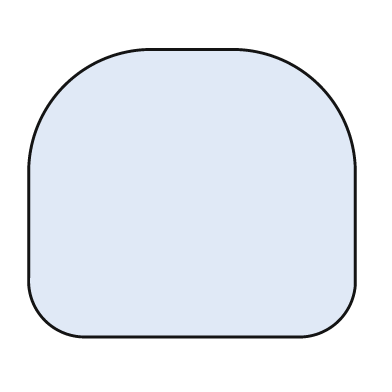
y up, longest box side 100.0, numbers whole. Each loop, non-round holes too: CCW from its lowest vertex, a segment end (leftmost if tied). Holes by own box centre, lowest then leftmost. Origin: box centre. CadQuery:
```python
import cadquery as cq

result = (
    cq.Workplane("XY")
    .moveTo(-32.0, -44.0)
    .lineTo(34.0, -44.0)
    .threePointArc((45.0, -39.0), (50.0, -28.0))
    .lineTo(50.0, 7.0)
    .threePointArc((39.0, 33.0), (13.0, 44.0))
    .lineTo(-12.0, 44.0)
    .threePointArc((-39.0, 33.0), (-50.0, 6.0))
    .lineTo(-50.0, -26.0)
    .threePointArc((-45.0, -39.0), (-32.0, -44.0))
    .close()
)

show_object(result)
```